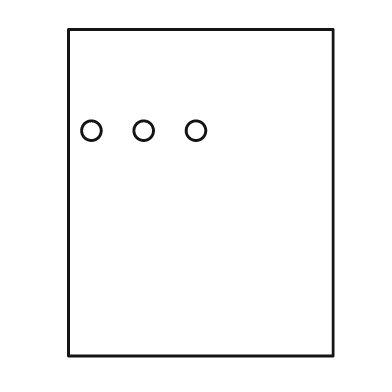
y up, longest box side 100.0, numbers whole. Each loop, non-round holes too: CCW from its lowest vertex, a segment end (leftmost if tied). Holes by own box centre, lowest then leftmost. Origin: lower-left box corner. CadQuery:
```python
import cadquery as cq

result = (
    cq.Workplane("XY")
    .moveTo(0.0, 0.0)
    .lineTo(81.0, 0.0)
    .lineTo(81.0, 100.0)
    .lineTo(0.0, 100.0)
    .close()
    .moveTo(7.0, 69.0)
    .circle(3.0)
    .moveTo(23.0, 69.0)
    .circle(3.0)
    .moveTo(39.0, 69.0)
    .circle(3.0)
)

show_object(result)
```